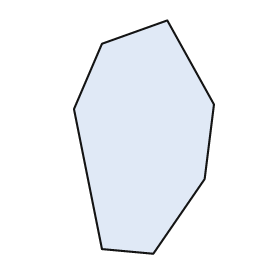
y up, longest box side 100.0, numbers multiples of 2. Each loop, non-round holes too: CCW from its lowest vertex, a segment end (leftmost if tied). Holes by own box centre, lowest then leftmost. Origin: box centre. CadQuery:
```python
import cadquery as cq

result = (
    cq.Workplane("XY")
    .moveTo(4.0, -50.0)
    .lineTo(26.0, -18.0)
    .lineTo(30.0, 14.0)
    .lineTo(10.0, 50.0)
    .lineTo(-18.0, 40.0)
    .lineTo(-30.0, 12.0)
    .lineTo(-18.0, -48.0)
    .close()
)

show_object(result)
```